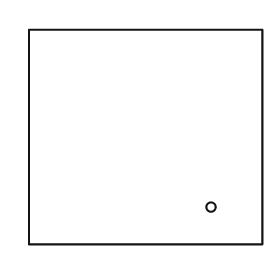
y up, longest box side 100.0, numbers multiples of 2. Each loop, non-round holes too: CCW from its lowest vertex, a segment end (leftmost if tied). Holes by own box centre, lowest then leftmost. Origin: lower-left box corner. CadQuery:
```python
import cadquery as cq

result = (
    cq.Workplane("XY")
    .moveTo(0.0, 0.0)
    .lineTo(100.0, 0.0)
    .lineTo(100.0, 92.0)
    .lineTo(0.0, 92.0)
    .close()
    .moveTo(78.0, 16.0)
    .circle(2.0)
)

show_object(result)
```